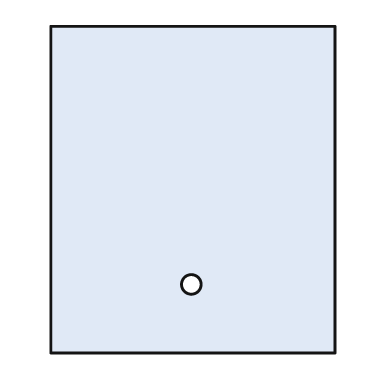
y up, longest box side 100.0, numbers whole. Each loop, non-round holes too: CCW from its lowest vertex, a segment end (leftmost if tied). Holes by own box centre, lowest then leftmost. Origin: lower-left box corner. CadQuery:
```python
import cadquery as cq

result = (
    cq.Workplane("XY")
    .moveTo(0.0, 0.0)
    .lineTo(87.0, 0.0)
    .lineTo(87.0, 100.0)
    .lineTo(0.0, 100.0)
    .close()
    .moveTo(43.0, 21.0)
    .circle(3.0)
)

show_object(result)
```